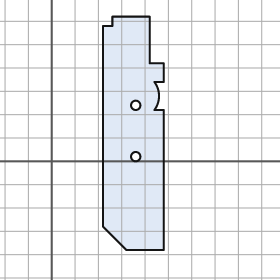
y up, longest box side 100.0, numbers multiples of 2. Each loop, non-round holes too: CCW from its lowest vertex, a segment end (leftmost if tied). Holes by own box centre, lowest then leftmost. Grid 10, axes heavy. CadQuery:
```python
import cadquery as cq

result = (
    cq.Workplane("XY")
    .moveTo(32.0, -38.0)
    .lineTo(48.0, -38.0)
    .lineTo(48.0, 22.0)
    .lineTo(44.0, 22.0)
    .threePointArc((46.0, 28.0), (44.0, 34.0))
    .lineTo(48.0, 34.0)
    .lineTo(48.0, 42.0)
    .lineTo(42.0, 42.0)
    .lineTo(42.0, 62.0)
    .lineTo(26.0, 62.0)
    .lineTo(26.0, 58.0)
    .lineTo(22.0, 58.0)
    .lineTo(22.0, -28.0)
    .close()
    .moveTo(36.0, 2.0)
    .circle(2.0)
    .moveTo(36.0, 24.0)
    .circle(2.0)
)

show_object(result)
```